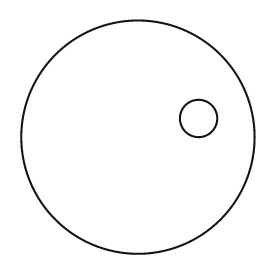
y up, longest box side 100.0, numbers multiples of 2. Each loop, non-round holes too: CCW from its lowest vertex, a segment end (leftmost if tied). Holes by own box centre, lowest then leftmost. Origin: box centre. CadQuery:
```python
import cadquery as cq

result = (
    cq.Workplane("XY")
    .moveTo(0.0, 0.0)
    .circle(50.0)
    .moveTo(26.0, 8.0)
    .circle(8.0)
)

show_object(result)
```